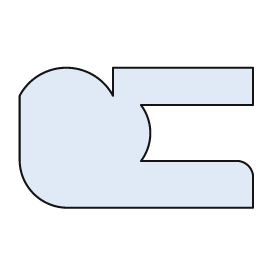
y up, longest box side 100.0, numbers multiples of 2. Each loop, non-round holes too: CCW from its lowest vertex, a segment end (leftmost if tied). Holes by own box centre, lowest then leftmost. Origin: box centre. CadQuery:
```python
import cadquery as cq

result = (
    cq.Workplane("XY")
    .moveTo(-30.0, -30.0)
    .lineTo(50.0, -30.0)
    .lineTo(50.0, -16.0)
    .threePointArc((48.0, -12.0), (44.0, -10.0))
    .lineTo(2.0, -10.0)
    .threePointArc((6.0, 2.0), (2.0, 14.0))
    .lineTo(50.0, 14.0)
    .lineTo(50.0, 30.0)
    .lineTo(-10.0, 30.0)
    .lineTo(-10.0, 18.0)
    .threePointArc((-30.0, 30.0), (-50.0, 18.0))
    .lineTo(-50.0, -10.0)
    .threePointArc((-44.0, -24.0), (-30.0, -30.0))
    .close()
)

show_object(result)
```